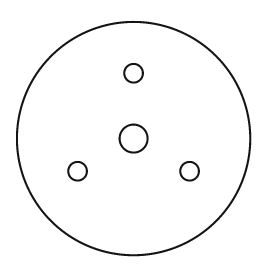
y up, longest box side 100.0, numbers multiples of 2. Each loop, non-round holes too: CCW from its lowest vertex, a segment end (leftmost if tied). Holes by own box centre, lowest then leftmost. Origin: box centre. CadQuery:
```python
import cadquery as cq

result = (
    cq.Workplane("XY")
    .moveTo(0.0, 0.0)
    .circle(50.0)
    .moveTo(-24.0, -14.0)
    .circle(4.0)
    .moveTo(24.0, -14.0)
    .circle(4.0)
    .moveTo(0.0, 0.0)
    .circle(6.0)
    .moveTo(0.0, 28.0)
    .circle(4.0)
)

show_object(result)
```